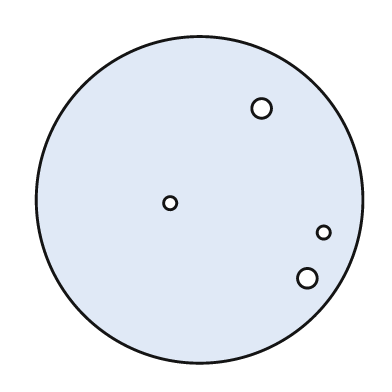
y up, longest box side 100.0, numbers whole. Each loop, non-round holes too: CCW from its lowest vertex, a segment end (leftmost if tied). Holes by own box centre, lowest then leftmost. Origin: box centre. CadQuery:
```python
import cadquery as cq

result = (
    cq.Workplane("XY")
    .moveTo(0.0, 0.0)
    .circle(50.0)
    .moveTo(33.0, -24.0)
    .circle(3.0)
    .moveTo(38.0, -10.0)
    .circle(2.0)
    .moveTo(-9.0, -1.0)
    .circle(2.0)
    .moveTo(19.0, 28.0)
    .circle(3.0)
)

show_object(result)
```